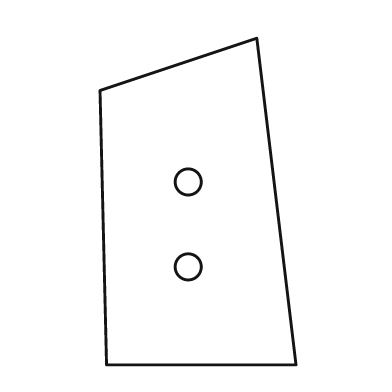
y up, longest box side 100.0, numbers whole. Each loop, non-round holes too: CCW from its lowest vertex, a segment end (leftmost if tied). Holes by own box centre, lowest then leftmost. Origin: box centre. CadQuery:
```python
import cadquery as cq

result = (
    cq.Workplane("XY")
    .moveTo(-28.0, -50.0)
    .lineTo(30.0, -50.0)
    .lineTo(18.0, 50.0)
    .lineTo(-30.0, 34.0)
    .close()
    .moveTo(-3.0, -20.0)
    .circle(4.0)
    .moveTo(-3.0, 6.0)
    .circle(4.0)
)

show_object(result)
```